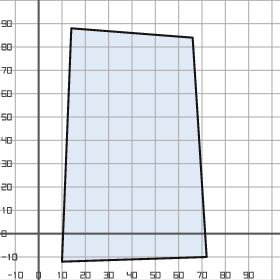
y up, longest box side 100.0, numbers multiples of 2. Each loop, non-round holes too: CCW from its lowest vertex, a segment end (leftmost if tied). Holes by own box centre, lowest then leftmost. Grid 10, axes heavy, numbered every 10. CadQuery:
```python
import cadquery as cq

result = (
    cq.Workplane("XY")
    .moveTo(10.0, -12.0)
    .lineTo(72.0, -10.0)
    .lineTo(66.0, 84.0)
    .lineTo(14.0, 88.0)
    .close()
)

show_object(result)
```